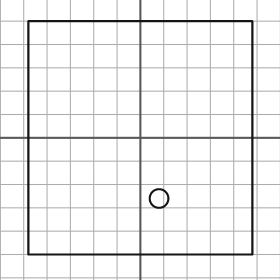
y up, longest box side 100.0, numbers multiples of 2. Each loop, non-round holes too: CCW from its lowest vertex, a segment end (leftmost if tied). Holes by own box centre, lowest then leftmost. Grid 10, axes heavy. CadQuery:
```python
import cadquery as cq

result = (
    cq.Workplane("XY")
    .moveTo(-48.0, -50.0)
    .lineTo(48.0, -50.0)
    .lineTo(48.0, 50.0)
    .lineTo(-48.0, 50.0)
    .close()
    .moveTo(8.0, -26.0)
    .circle(4.0)
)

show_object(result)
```